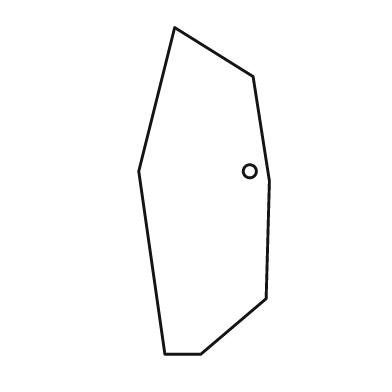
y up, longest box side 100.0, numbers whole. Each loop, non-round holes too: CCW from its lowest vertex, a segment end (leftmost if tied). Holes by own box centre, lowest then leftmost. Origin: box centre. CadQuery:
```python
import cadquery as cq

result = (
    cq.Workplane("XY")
    .moveTo(-12.0, -50.0)
    .lineTo(-1.0, -50.0)
    .lineTo(19.0, -33.0)
    .lineTo(20.0, 3.0)
    .lineTo(15.0, 35.0)
    .lineTo(-9.0, 50.0)
    .lineTo(-20.0, 6.0)
    .close()
    .moveTo(14.0, 6.0)
    .circle(2.0)
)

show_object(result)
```